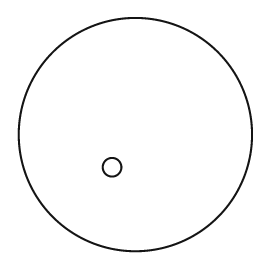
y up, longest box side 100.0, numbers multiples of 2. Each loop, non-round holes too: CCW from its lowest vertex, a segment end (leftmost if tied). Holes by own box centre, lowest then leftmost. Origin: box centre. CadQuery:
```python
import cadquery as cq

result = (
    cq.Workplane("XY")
    .moveTo(0.0, 0.0)
    .circle(50.0)
    .moveTo(-10.0, -14.0)
    .circle(4.0)
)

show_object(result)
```